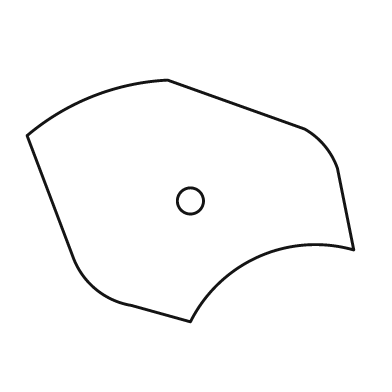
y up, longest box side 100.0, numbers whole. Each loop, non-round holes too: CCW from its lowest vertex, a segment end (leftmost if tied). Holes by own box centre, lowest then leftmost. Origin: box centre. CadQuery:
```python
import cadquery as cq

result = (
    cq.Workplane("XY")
    .moveTo(0.0, -37.0)
    .threePointArc((21.0, -17.0), (50.0, -15.0))
    .lineTo(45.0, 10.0)
    .threePointArc((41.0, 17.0), (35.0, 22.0))
    .lineTo(-7.0, 37.0)
    .threePointArc((-30.0, 32.0), (-50.0, 20.0))
    .lineTo(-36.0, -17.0)
    .threePointArc((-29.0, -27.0), (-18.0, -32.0))
    .close()
    .moveTo(0.0, 0.0)
    .circle(4.0)
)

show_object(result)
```